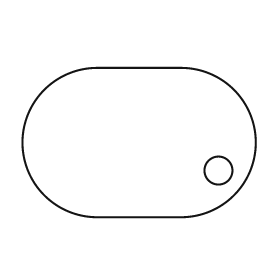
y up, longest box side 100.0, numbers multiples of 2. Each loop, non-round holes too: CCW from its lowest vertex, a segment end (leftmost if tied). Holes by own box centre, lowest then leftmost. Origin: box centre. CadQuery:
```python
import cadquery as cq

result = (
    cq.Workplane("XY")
    .moveTo(-18.0, -32.0)
    .lineTo(18.0, -32.0)
    .threePointArc((50.0, 0.0), (18.0, 32.0))
    .lineTo(-18.0, 32.0)
    .threePointArc((-50.0, 0.0), (-18.0, -32.0))
    .close()
    .moveTo(34.0, -12.0)
    .circle(6.0)
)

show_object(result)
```